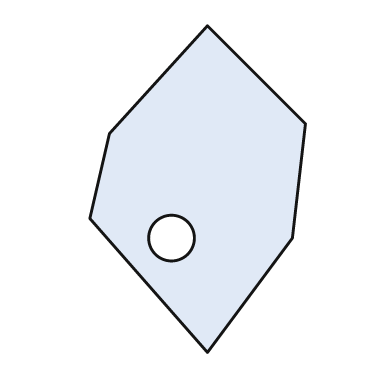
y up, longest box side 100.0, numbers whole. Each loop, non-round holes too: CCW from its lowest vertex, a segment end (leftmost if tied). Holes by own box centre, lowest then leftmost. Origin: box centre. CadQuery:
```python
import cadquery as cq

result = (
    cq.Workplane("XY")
    .moveTo(3.0, -50.0)
    .lineTo(29.0, -15.0)
    .lineTo(33.0, 20.0)
    .lineTo(3.0, 50.0)
    .lineTo(-27.0, 17.0)
    .lineTo(-33.0, -9.0)
    .close()
    .moveTo(-8.0, -15.0)
    .circle(7.0)
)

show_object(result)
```